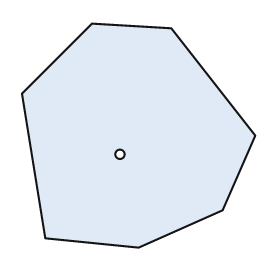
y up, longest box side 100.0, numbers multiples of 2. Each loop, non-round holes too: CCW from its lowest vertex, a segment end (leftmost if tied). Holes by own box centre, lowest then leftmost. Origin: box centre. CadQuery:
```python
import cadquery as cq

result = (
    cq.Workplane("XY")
    .moveTo(0.0, -48.0)
    .lineTo(36.0, -32.0)
    .lineTo(50.0, 0.0)
    .lineTo(14.0, 46.0)
    .lineTo(-20.0, 48.0)
    .lineTo(-50.0, 18.0)
    .lineTo(-40.0, -44.0)
    .close()
    .moveTo(-8.0, -8.0)
    .circle(2.0)
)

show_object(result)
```